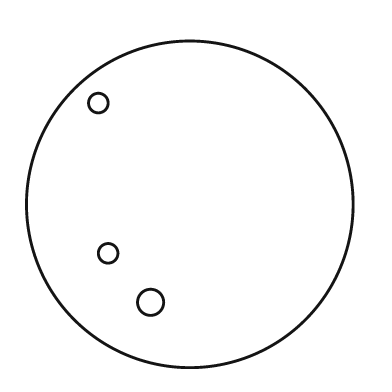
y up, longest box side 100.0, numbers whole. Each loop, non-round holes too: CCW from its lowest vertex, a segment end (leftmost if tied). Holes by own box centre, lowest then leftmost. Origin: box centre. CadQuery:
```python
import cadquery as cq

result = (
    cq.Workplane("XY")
    .moveTo(0.0, 0.0)
    .circle(50.0)
    .moveTo(-12.0, -30.0)
    .circle(4.0)
    .moveTo(-25.0, -15.0)
    .circle(3.0)
    .moveTo(-28.0, 31.0)
    .circle(3.0)
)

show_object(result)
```